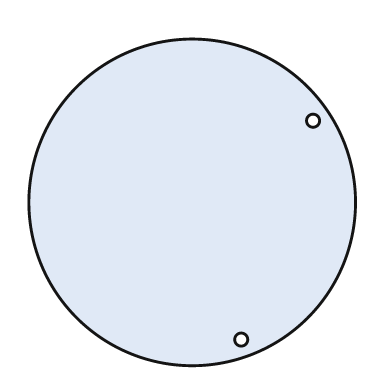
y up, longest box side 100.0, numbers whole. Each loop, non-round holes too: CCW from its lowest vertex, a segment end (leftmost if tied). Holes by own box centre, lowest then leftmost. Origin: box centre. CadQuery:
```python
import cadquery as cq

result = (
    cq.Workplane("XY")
    .moveTo(0.0, 0.0)
    .circle(50.0)
    .moveTo(15.0, -42.0)
    .circle(2.0)
    .moveTo(37.0, 25.0)
    .circle(2.0)
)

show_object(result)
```